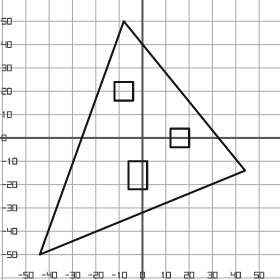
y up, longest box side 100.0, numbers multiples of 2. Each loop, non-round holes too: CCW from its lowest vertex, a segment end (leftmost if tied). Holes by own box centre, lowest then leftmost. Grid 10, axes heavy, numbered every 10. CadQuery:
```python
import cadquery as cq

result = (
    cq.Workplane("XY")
    .moveTo(-44.0, -50.0)
    .lineTo(44.0, -14.0)
    .lineTo(-8.0, 50.0)
    .close()
    .moveTo(-6.0, -22.0)
    .lineTo(2.0, -22.0)
    .lineTo(2.0, -10.0)
    .lineTo(-6.0, -10.0)
    .close()
    .moveTo(12.0, -4.0)
    .lineTo(20.0, -4.0)
    .lineTo(20.0, 4.0)
    .lineTo(12.0, 4.0)
    .close()
    .moveTo(-12.0, 16.0)
    .lineTo(-4.0, 16.0)
    .lineTo(-4.0, 24.0)
    .lineTo(-12.0, 24.0)
    .close()
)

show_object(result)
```